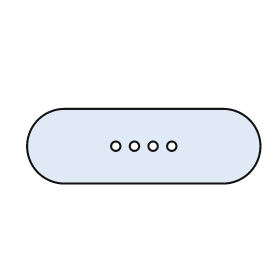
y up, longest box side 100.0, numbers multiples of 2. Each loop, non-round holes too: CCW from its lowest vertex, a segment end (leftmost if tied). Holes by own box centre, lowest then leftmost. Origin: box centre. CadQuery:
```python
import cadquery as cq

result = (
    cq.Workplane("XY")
    .moveTo(-34.0, -16.0)
    .lineTo(34.0, -16.0)
    .threePointArc((50.0, 0.0), (34.0, 16.0))
    .lineTo(-34.0, 16.0)
    .threePointArc((-50.0, 0.0), (-34.0, -16.0))
    .close()
    .moveTo(-12.0, 0.0)
    .circle(2.0)
    .moveTo(-4.0, 0.0)
    .circle(2.0)
    .moveTo(4.0, 0.0)
    .circle(2.0)
    .moveTo(12.0, 0.0)
    .circle(2.0)
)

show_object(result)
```